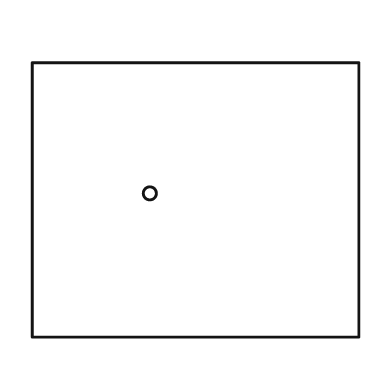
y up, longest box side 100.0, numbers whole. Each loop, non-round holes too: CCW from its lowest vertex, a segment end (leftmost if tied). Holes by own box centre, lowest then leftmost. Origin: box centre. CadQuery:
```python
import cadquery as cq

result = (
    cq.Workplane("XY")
    .moveTo(-50.0, -42.0)
    .lineTo(50.0, -42.0)
    .lineTo(50.0, 42.0)
    .lineTo(-50.0, 42.0)
    .close()
    .moveTo(-14.0, 2.0)
    .circle(2.0)
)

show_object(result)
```